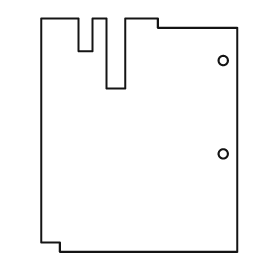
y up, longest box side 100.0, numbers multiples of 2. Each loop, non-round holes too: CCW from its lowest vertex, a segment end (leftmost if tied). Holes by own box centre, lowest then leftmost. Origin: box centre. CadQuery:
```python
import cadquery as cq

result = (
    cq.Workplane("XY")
    .moveTo(-34.0, -50.0)
    .lineTo(42.0, -50.0)
    .lineTo(42.0, 46.0)
    .lineTo(8.0, 46.0)
    .lineTo(8.0, 50.0)
    .lineTo(-6.0, 50.0)
    .lineTo(-6.0, 20.0)
    .lineTo(-14.0, 20.0)
    .lineTo(-14.0, 50.0)
    .lineTo(-20.0, 50.0)
    .lineTo(-20.0, 36.0)
    .lineTo(-26.0, 36.0)
    .lineTo(-26.0, 50.0)
    .lineTo(-42.0, 50.0)
    .lineTo(-42.0, -46.0)
    .lineTo(-34.0, -46.0)
    .close()
    .moveTo(36.0, -8.0)
    .circle(2.0)
    .moveTo(36.0, 32.0)
    .circle(2.0)
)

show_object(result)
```